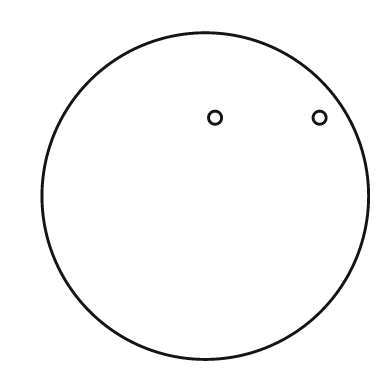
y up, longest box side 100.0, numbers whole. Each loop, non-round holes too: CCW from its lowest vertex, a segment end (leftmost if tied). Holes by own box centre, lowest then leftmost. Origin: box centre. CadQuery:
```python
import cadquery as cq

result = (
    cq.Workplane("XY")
    .moveTo(0.0, 0.0)
    .circle(50.0)
    .moveTo(3.0, 24.0)
    .circle(2.0)
    .moveTo(35.0, 24.0)
    .circle(2.0)
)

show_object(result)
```